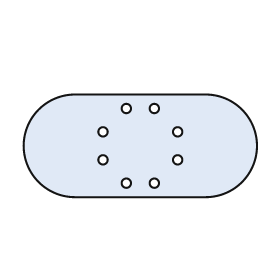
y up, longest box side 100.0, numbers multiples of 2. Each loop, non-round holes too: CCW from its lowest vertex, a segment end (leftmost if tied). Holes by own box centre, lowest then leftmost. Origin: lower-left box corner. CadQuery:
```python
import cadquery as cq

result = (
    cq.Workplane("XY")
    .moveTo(22.0, 0.0)
    .lineTo(78.0, 0.0)
    .threePointArc((100.0, 22.0), (78.0, 44.0))
    .lineTo(22.0, 44.0)
    .threePointArc((0.0, 22.0), (22.0, 0.0))
    .close()
    .moveTo(44.0, 6.0)
    .circle(2.0)
    .moveTo(56.0, 6.0)
    .circle(2.0)
    .moveTo(34.0, 16.0)
    .circle(2.0)
    .moveTo(66.0, 16.0)
    .circle(2.0)
    .moveTo(34.0, 28.0)
    .circle(2.0)
    .moveTo(66.0, 28.0)
    .circle(2.0)
    .moveTo(44.0, 38.0)
    .circle(2.0)
    .moveTo(56.0, 38.0)
    .circle(2.0)
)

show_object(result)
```